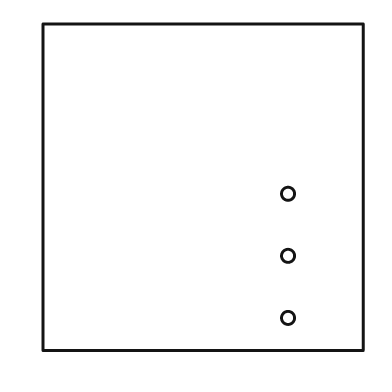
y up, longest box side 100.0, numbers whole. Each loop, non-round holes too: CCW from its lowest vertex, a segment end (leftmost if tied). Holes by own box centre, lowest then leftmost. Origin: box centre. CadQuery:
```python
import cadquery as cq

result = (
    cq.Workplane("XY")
    .moveTo(-49.0, -50.0)
    .lineTo(49.0, -50.0)
    .lineTo(49.0, 50.0)
    .lineTo(-49.0, 50.0)
    .close()
    .moveTo(26.0, -40.0)
    .circle(2.0)
    .moveTo(26.0, -21.0)
    .circle(2.0)
    .moveTo(26.0, -2.0)
    .circle(2.0)
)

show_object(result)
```